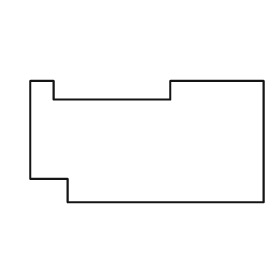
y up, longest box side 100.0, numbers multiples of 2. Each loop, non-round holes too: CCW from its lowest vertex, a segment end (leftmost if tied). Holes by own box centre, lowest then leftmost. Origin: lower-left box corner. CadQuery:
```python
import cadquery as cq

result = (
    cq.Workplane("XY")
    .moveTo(16.0, 0.0)
    .lineTo(100.0, 0.0)
    .lineTo(100.0, 52.0)
    .lineTo(60.0, 52.0)
    .lineTo(60.0, 44.0)
    .lineTo(10.0, 44.0)
    .lineTo(10.0, 52.0)
    .lineTo(0.0, 52.0)
    .lineTo(0.0, 10.0)
    .lineTo(16.0, 10.0)
    .close()
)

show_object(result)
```